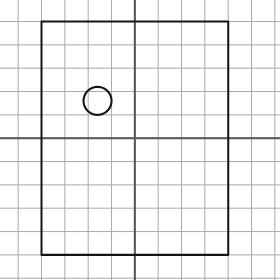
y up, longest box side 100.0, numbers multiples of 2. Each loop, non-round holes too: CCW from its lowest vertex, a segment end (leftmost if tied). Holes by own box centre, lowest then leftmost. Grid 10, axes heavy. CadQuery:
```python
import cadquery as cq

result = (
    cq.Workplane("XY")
    .moveTo(-40.0, -50.0)
    .lineTo(40.0, -50.0)
    .lineTo(40.0, 50.0)
    .lineTo(-40.0, 50.0)
    .close()
    .moveTo(-16.0, 16.0)
    .circle(6.0)
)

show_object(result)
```